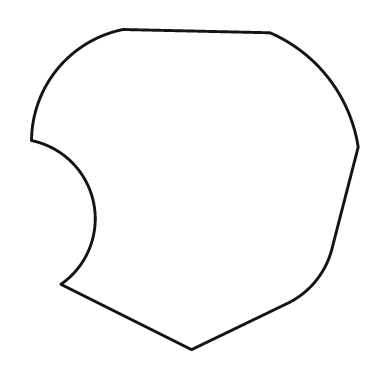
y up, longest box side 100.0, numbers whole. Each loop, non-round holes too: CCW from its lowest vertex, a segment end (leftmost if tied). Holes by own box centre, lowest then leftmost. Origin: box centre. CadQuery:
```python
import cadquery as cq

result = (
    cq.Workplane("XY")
    .moveTo(-1.0, -49.0)
    .lineTo(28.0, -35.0)
    .threePointArc((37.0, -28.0), (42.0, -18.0))
    .lineTo(50.0, 13.0)
    .threePointArc((41.0, 34.0), (23.0, 48.0))
    .lineTo(-22.0, 49.0)
    .threePointArc((-42.0, 37.0), (-50.0, 15.0))
    .threePointArc((-31.0, -4.0), (-41.0, -29.0))
    .close()
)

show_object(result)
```